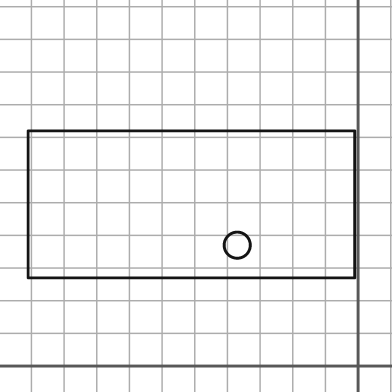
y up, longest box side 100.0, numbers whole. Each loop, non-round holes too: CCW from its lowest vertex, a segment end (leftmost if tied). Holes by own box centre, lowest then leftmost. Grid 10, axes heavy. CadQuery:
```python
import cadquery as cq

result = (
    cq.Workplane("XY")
    .moveTo(-101.0, 27.0)
    .lineTo(-1.0, 27.0)
    .lineTo(-1.0, 72.0)
    .lineTo(-101.0, 72.0)
    .close()
    .moveTo(-37.0, 37.0)
    .circle(4.0)
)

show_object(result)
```